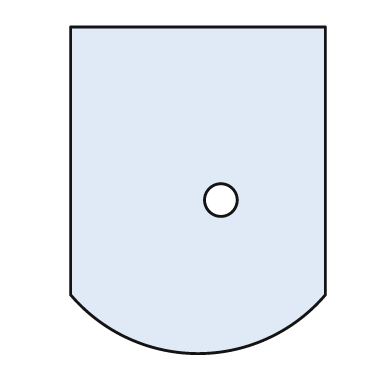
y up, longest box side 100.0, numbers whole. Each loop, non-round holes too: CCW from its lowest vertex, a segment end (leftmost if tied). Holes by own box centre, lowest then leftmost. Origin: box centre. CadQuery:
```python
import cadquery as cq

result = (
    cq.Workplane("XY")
    .moveTo(-39.0, -32.0)
    .threePointArc((0.0, -50.0), (39.0, -32.0))
    .lineTo(39.0, 50.0)
    .lineTo(-39.0, 50.0)
    .close()
    .moveTo(7.0, -3.0)
    .circle(5.0)
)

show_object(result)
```